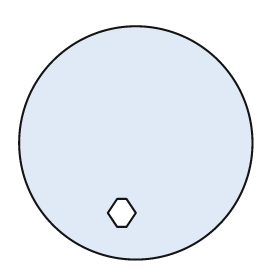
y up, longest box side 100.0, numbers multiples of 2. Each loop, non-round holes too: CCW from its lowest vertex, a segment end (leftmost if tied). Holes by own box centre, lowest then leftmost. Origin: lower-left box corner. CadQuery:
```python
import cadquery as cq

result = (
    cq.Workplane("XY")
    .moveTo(50.0, 50.0)
    .circle(50.0)
    .moveTo(42.0, 14.0)
    .lineTo(46.0, 14.0)
    .lineTo(50.0, 20.0)
    .lineTo(46.0, 26.0)
    .lineTo(42.0, 26.0)
    .lineTo(38.0, 20.0)
    .close()
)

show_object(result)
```